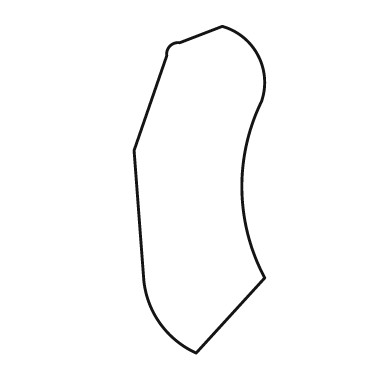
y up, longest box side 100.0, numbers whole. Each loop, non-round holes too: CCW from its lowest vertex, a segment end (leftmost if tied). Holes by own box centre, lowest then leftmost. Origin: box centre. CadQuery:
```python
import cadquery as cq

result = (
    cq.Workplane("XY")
    .moveTo(-1.0, -50.0)
    .lineTo(20.0, -27.0)
    .threePointArc((13.0, 0.0), (19.0, 27.0))
    .threePointArc((18.0, 41.0), (7.0, 50.0))
    .lineTo(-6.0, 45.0)
    .threePointArc((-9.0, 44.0), (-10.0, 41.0))
    .lineTo(-20.0, 12.0)
    .lineTo(-17.0, -28.0)
    .threePointArc((-12.0, -41.0), (-1.0, -50.0))
    .close()
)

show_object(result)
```